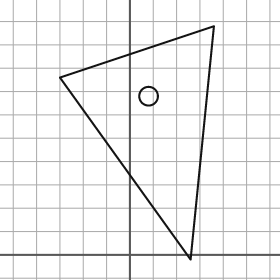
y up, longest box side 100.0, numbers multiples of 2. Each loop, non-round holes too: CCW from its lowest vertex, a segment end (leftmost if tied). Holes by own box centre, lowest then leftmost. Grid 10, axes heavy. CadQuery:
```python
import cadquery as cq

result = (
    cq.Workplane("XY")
    .moveTo(26.0, -2.0)
    .lineTo(36.0, 98.0)
    .lineTo(-30.0, 76.0)
    .close()
    .moveTo(8.0, 68.0)
    .circle(4.0)
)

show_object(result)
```